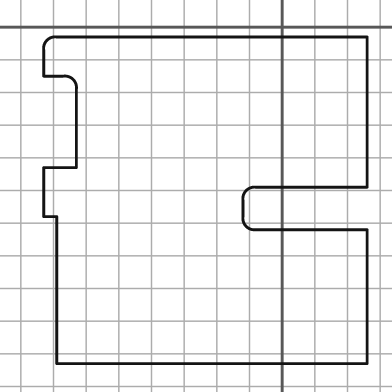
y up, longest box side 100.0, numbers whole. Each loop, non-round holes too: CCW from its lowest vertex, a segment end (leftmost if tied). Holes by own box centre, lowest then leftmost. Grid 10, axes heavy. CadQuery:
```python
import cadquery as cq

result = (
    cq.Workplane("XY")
    .moveTo(-69.0, -103.0)
    .lineTo(26.0, -103.0)
    .lineTo(26.0, -62.0)
    .lineTo(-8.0, -62.0)
    .threePointArc((-11.0, -61.0), (-12.0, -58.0))
    .lineTo(-12.0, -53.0)
    .threePointArc((-11.0, -50.0), (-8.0, -49.0))
    .lineTo(26.0, -49.0)
    .lineTo(26.0, -3.0)
    .lineTo(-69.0, -3.0)
    .threePointArc((-72.0, -4.0), (-73.0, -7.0))
    .lineTo(-73.0, -15.0)
    .lineTo(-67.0, -15.0)
    .threePointArc((-64.0, -16.0), (-63.0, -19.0))
    .lineTo(-63.0, -43.0)
    .lineTo(-73.0, -43.0)
    .lineTo(-73.0, -58.0)
    .lineTo(-69.0, -58.0)
    .close()
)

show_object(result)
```